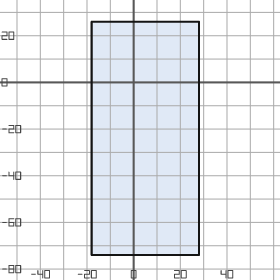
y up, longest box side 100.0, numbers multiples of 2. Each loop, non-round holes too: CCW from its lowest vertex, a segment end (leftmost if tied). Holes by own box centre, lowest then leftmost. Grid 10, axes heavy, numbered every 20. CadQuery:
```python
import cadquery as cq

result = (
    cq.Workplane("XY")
    .moveTo(-18.0, -74.0)
    .lineTo(28.0, -74.0)
    .lineTo(28.0, 26.0)
    .lineTo(-18.0, 26.0)
    .close()
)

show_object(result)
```